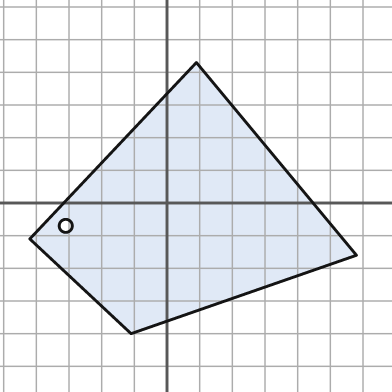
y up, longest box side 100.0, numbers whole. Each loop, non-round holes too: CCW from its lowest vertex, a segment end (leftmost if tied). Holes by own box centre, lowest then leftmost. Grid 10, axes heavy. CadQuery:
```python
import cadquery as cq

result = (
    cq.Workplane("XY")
    .moveTo(-11.0, -40.0)
    .lineTo(58.0, -16.0)
    .lineTo(9.0, 43.0)
    .lineTo(-42.0, -11.0)
    .close()
    .moveTo(-31.0, -7.0)
    .circle(2.0)
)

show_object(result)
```